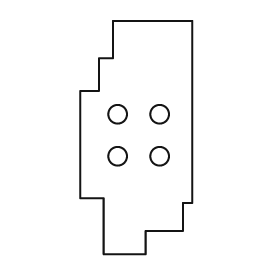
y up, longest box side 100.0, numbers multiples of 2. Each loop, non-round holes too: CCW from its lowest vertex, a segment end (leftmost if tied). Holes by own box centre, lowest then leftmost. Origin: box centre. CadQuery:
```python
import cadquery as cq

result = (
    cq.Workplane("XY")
    .moveTo(-14.0, -50.0)
    .lineTo(4.0, -50.0)
    .lineTo(4.0, -40.0)
    .lineTo(20.0, -40.0)
    .lineTo(20.0, -28.0)
    .lineTo(24.0, -28.0)
    .lineTo(24.0, 50.0)
    .lineTo(-10.0, 50.0)
    .lineTo(-10.0, 34.0)
    .lineTo(-16.0, 34.0)
    .lineTo(-16.0, 20.0)
    .lineTo(-24.0, 20.0)
    .lineTo(-24.0, -26.0)
    .lineTo(-14.0, -26.0)
    .close()
    .moveTo(-8.0, -8.0)
    .circle(4.0)
    .moveTo(10.0, -8.0)
    .circle(4.0)
    .moveTo(-8.0, 10.0)
    .circle(4.0)
    .moveTo(10.0, 10.0)
    .circle(4.0)
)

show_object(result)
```